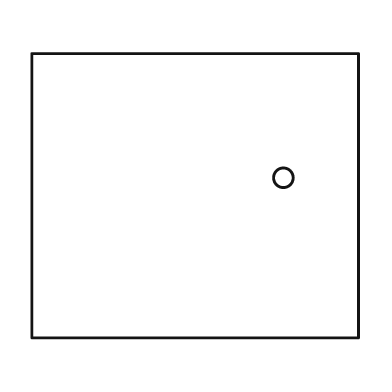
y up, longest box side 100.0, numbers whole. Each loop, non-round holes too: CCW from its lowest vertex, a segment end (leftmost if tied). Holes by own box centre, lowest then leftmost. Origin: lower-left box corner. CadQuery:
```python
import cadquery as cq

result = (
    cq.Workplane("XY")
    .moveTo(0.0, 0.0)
    .lineTo(100.0, 0.0)
    .lineTo(100.0, 87.0)
    .lineTo(0.0, 87.0)
    .close()
    .moveTo(77.0, 49.0)
    .circle(3.0)
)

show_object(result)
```